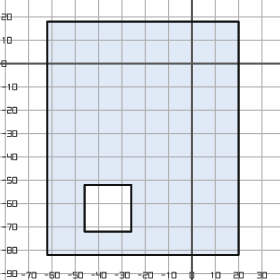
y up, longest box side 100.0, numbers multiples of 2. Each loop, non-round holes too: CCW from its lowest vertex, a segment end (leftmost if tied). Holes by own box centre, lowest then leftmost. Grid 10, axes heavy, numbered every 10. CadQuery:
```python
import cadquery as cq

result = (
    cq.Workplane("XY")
    .moveTo(-62.0, -82.0)
    .lineTo(20.0, -82.0)
    .lineTo(20.0, 18.0)
    .lineTo(-62.0, 18.0)
    .close()
    .moveTo(-46.0, -72.0)
    .lineTo(-26.0, -72.0)
    .lineTo(-26.0, -52.0)
    .lineTo(-46.0, -52.0)
    .close()
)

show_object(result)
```